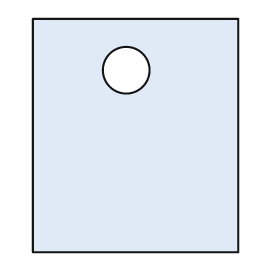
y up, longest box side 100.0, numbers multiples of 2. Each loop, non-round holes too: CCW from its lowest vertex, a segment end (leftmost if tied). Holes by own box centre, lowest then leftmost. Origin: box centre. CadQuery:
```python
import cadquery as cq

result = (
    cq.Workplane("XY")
    .moveTo(-44.0, -50.0)
    .lineTo(44.0, -50.0)
    .lineTo(44.0, 50.0)
    .lineTo(-44.0, 50.0)
    .close()
    .moveTo(-4.0, 28.0)
    .circle(10.0)
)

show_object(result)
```